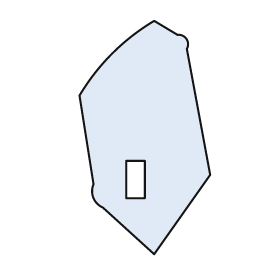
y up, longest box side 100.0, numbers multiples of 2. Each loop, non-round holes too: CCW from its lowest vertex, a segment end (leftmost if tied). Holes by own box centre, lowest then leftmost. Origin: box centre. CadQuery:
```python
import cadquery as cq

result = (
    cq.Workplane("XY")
    .moveTo(4.0, -50.0)
    .lineTo(28.0, -16.0)
    .lineTo(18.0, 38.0)
    .threePointArc((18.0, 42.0), (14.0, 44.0))
    .lineTo(4.0, 50.0)
    .threePointArc((-14.0, 36.0), (-28.0, 18.0))
    .lineTo(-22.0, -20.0)
    .threePointArc((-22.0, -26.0), (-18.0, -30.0))
    .close()
    .moveTo(-8.0, -26.0)
    .lineTo(0.0, -26.0)
    .lineTo(0.0, -10.0)
    .lineTo(-8.0, -10.0)
    .close()
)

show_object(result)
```